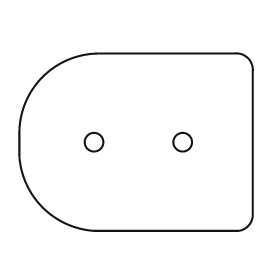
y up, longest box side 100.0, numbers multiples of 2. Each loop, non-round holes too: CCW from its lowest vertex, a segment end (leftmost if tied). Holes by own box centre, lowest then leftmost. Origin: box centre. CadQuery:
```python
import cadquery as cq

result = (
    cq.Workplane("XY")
    .moveTo(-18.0, -38.0)
    .lineTo(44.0, -38.0)
    .threePointArc((48.0, -36.0), (50.0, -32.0))
    .lineTo(50.0, 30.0)
    .threePointArc((48.0, 36.0), (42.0, 38.0))
    .lineTo(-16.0, 38.0)
    .threePointArc((-40.0, 28.0), (-50.0, 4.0))
    .lineTo(-50.0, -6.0)
    .threePointArc((-40.0, -28.0), (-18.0, -38.0))
    .close()
    .moveTo(-18.0, 0.0)
    .circle(4.0)
    .moveTo(20.0, 0.0)
    .circle(4.0)
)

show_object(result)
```